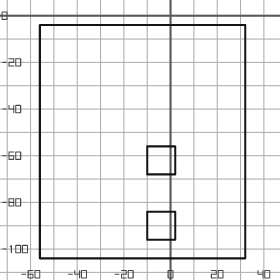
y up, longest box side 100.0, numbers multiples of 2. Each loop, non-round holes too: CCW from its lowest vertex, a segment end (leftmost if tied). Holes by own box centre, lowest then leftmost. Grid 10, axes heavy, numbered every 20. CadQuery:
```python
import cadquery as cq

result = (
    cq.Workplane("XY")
    .moveTo(-56.0, -104.0)
    .lineTo(32.0, -104.0)
    .lineTo(32.0, -4.0)
    .lineTo(-56.0, -4.0)
    .close()
    .moveTo(-10.0, -96.0)
    .lineTo(2.0, -96.0)
    .lineTo(2.0, -84.0)
    .lineTo(-10.0, -84.0)
    .close()
    .moveTo(-10.0, -68.0)
    .lineTo(2.0, -68.0)
    .lineTo(2.0, -56.0)
    .lineTo(-10.0, -56.0)
    .close()
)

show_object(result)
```